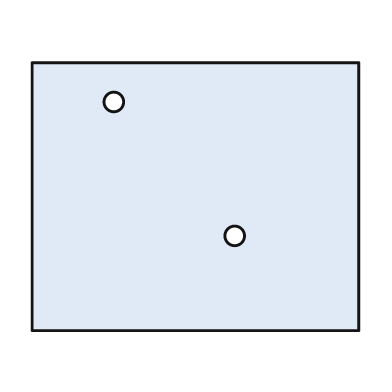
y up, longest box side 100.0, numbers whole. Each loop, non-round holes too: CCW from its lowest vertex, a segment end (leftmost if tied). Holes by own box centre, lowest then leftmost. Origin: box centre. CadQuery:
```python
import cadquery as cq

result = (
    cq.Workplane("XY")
    .moveTo(-50.0, -41.0)
    .lineTo(50.0, -41.0)
    .lineTo(50.0, 41.0)
    .lineTo(-50.0, 41.0)
    .close()
    .moveTo(12.0, -12.0)
    .circle(3.0)
    .moveTo(-25.0, 29.0)
    .circle(3.0)
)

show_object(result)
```